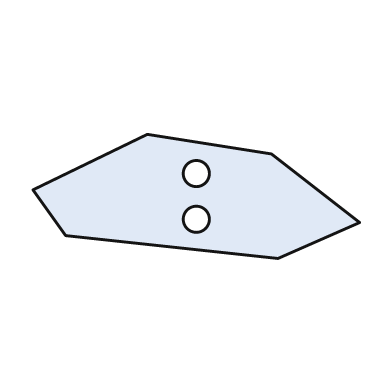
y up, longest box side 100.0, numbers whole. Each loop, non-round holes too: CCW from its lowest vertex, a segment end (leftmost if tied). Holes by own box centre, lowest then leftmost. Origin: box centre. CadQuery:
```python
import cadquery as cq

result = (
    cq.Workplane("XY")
    .moveTo(25.0, -19.0)
    .lineTo(50.0, -8.0)
    .lineTo(23.0, 13.0)
    .lineTo(-15.0, 19.0)
    .lineTo(-50.0, 2.0)
    .lineTo(-40.0, -12.0)
    .close()
    .moveTo(0.0, -7.0)
    .circle(4.0)
    .moveTo(0.0, 7.0)
    .circle(4.0)
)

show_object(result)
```